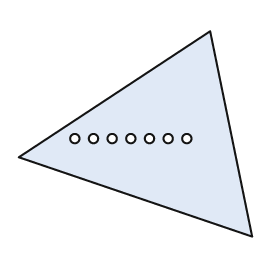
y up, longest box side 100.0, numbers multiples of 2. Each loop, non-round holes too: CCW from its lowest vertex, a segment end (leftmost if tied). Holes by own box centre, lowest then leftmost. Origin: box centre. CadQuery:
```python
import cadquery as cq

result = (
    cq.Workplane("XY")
    .moveTo(50.0, -44.0)
    .lineTo(32.0, 44.0)
    .lineTo(-50.0, -10.0)
    .close()
    .moveTo(-26.0, -2.0)
    .circle(2.0)
    .moveTo(-18.0, -2.0)
    .circle(2.0)
    .moveTo(-10.0, -2.0)
    .circle(2.0)
    .moveTo(-2.0, -2.0)
    .circle(2.0)
    .moveTo(6.0, -2.0)
    .circle(2.0)
    .moveTo(14.0, -2.0)
    .circle(2.0)
    .moveTo(22.0, -2.0)
    .circle(2.0)
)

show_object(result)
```